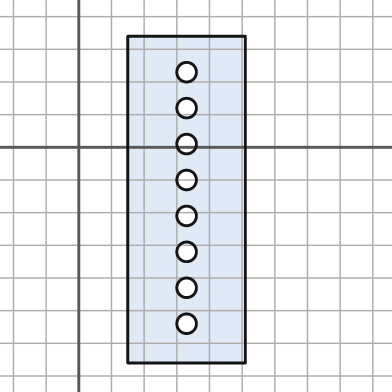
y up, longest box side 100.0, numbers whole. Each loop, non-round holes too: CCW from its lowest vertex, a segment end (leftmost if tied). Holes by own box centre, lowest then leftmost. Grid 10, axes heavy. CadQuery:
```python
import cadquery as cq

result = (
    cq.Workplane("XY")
    .moveTo(15.0, -66.0)
    .lineTo(51.0, -66.0)
    .lineTo(51.0, 34.0)
    .lineTo(15.0, 34.0)
    .close()
    .moveTo(33.0, -54.0)
    .circle(3.0)
    .moveTo(33.0, -43.0)
    .circle(3.0)
    .moveTo(33.0, -32.0)
    .circle(3.0)
    .moveTo(33.0, -21.0)
    .circle(3.0)
    .moveTo(33.0, -10.0)
    .circle(3.0)
    .moveTo(33.0, 1.0)
    .circle(3.0)
    .moveTo(33.0, 12.0)
    .circle(3.0)
    .moveTo(33.0, 23.0)
    .circle(3.0)
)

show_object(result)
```